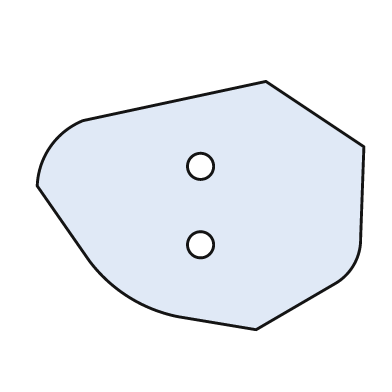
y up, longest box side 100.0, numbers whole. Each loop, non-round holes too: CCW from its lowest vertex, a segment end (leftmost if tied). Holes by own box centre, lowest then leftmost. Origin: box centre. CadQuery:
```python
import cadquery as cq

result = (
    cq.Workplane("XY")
    .moveTo(17.0, -38.0)
    .lineTo(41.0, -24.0)
    .threePointArc((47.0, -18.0), (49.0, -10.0))
    .lineTo(50.0, 18.0)
    .lineTo(20.0, 38.0)
    .lineTo(-36.0, 26.0)
    .threePointArc((-46.0, 18.0), (-50.0, 6.0))
    .lineTo(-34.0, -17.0)
    .threePointArc((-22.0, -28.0), (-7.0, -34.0))
    .close()
    .moveTo(0.0, -12.0)
    .circle(4.0)
    .moveTo(0.0, 12.0)
    .circle(4.0)
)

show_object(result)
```